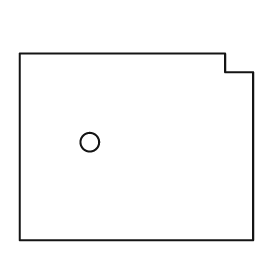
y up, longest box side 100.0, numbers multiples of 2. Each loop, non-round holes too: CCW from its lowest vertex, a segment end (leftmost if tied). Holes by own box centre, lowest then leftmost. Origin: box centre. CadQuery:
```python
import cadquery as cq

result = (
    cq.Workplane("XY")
    .moveTo(-50.0, -40.0)
    .lineTo(50.0, -40.0)
    .lineTo(50.0, 32.0)
    .lineTo(38.0, 32.0)
    .lineTo(38.0, 40.0)
    .lineTo(-50.0, 40.0)
    .close()
    .moveTo(-20.0, 2.0)
    .circle(4.0)
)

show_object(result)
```